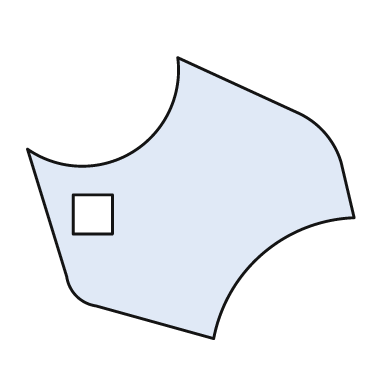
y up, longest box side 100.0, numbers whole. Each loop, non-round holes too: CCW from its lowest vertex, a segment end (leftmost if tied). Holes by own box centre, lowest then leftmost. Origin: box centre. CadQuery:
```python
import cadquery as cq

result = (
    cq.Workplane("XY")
    .moveTo(7.0, -43.0)
    .threePointArc((22.0, -17.0), (50.0, -6.0))
    .lineTo(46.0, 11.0)
    .threePointArc((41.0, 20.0), (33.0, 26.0))
    .lineTo(-4.0, 43.0)
    .threePointArc((-18.0, 14.0), (-50.0, 15.0))
    .lineTo(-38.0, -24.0)
    .threePointArc((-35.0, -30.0), (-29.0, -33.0))
    .close()
    .moveTo(-36.0, -11.0)
    .lineTo(-24.0, -11.0)
    .lineTo(-24.0, 1.0)
    .lineTo(-36.0, 1.0)
    .close()
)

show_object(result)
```